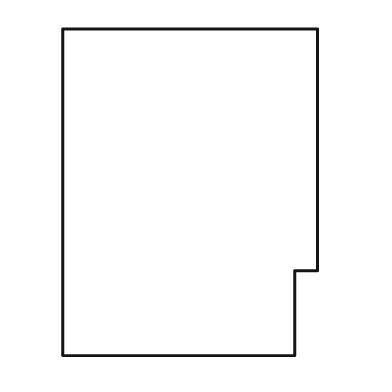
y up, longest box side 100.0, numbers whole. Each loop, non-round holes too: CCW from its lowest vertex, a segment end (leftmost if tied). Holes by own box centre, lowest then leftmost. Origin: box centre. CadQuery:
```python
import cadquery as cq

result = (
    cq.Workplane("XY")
    .moveTo(-39.0, -50.0)
    .lineTo(32.0, -50.0)
    .lineTo(32.0, -24.0)
    .lineTo(39.0, -24.0)
    .lineTo(39.0, 50.0)
    .lineTo(-39.0, 50.0)
    .close()
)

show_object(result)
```